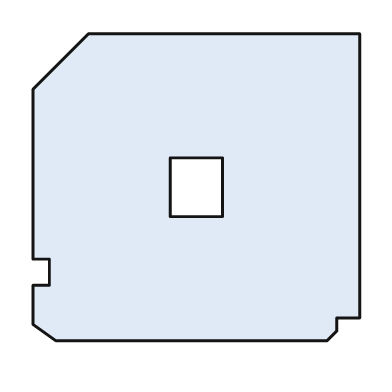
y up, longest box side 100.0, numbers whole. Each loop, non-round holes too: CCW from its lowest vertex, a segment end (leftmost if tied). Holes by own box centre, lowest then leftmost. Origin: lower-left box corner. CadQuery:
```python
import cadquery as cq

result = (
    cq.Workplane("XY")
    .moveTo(7.0, 0.0)
    .lineTo(90.0, 0.0)
    .lineTo(93.0, 3.0)
    .lineTo(93.0, 7.0)
    .lineTo(100.0, 7.0)
    .lineTo(100.0, 94.0)
    .lineTo(17.0, 94.0)
    .lineTo(0.0, 77.0)
    .lineTo(0.0, 25.0)
    .lineTo(5.0, 25.0)
    .lineTo(5.0, 17.0)
    .lineTo(0.0, 17.0)
    .lineTo(0.0, 5.0)
    .close()
    .moveTo(42.0, 38.0)
    .lineTo(58.0, 38.0)
    .lineTo(58.0, 56.0)
    .lineTo(42.0, 56.0)
    .close()
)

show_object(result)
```